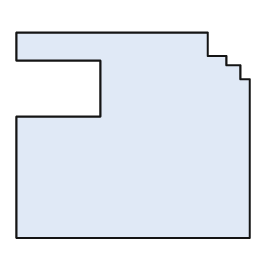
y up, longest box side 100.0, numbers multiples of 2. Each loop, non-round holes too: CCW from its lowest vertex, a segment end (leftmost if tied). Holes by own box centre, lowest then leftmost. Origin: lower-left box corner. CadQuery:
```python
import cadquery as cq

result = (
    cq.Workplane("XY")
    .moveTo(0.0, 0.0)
    .lineTo(100.0, 0.0)
    .lineTo(100.0, 68.0)
    .lineTo(96.0, 68.0)
    .lineTo(96.0, 74.0)
    .lineTo(90.0, 74.0)
    .lineTo(90.0, 78.0)
    .lineTo(82.0, 78.0)
    .lineTo(82.0, 88.0)
    .lineTo(0.0, 88.0)
    .lineTo(0.0, 76.0)
    .lineTo(36.0, 76.0)
    .lineTo(36.0, 52.0)
    .lineTo(0.0, 52.0)
    .close()
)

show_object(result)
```